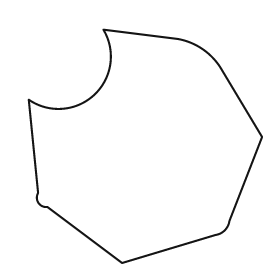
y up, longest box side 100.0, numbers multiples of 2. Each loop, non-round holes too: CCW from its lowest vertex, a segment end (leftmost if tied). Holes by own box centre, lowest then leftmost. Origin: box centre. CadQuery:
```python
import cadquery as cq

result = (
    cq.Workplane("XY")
    .moveTo(-10.0, -50.0)
    .lineTo(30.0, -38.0)
    .threePointArc((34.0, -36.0), (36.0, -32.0))
    .lineTo(50.0, 4.0)
    .lineTo(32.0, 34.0)
    .threePointArc((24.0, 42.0), (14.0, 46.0))
    .lineTo(-18.0, 50.0)
    .threePointArc((-22.0, 22.0), (-50.0, 20.0))
    .lineTo(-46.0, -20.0)
    .threePointArc((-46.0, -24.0), (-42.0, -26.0))
    .close()
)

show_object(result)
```